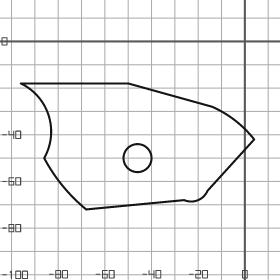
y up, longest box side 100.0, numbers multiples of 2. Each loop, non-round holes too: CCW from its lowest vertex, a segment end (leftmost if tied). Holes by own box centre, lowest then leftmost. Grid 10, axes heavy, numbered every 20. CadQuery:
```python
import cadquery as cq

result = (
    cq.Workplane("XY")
    .moveTo(-68.0, -72.0)
    .lineTo(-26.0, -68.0)
    .threePointArc((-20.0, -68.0), (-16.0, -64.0))
    .lineTo(4.0, -42.0)
    .threePointArc((-4.0, -34.0), (-14.0, -28.0))
    .lineTo(-50.0, -18.0)
    .lineTo(-96.0, -18.0)
    .threePointArc((-84.0, -32.0), (-86.0, -50.0))
    .threePointArc((-78.0, -62.0), (-68.0, -72.0))
    .close()
    .moveTo(-46.0, -50.0)
    .circle(6.0)
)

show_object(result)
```